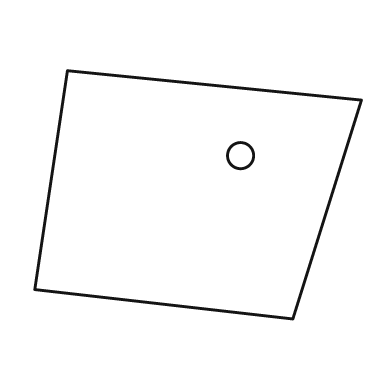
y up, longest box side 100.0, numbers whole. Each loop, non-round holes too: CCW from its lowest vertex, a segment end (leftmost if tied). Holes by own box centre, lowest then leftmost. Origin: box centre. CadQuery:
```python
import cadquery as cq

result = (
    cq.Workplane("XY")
    .moveTo(29.0, -38.0)
    .lineTo(50.0, 29.0)
    .lineTo(-40.0, 38.0)
    .lineTo(-50.0, -29.0)
    .close()
    .moveTo(13.0, 12.0)
    .circle(4.0)
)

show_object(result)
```